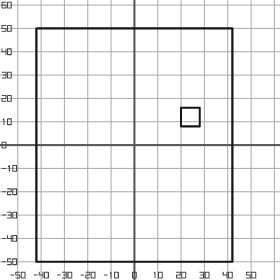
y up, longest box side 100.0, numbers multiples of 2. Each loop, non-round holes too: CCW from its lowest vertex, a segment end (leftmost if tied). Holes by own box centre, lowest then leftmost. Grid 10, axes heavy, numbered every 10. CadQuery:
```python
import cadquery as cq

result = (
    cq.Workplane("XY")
    .moveTo(-42.0, -50.0)
    .lineTo(42.0, -50.0)
    .lineTo(42.0, 50.0)
    .lineTo(-42.0, 50.0)
    .close()
    .moveTo(20.0, 8.0)
    .lineTo(28.0, 8.0)
    .lineTo(28.0, 16.0)
    .lineTo(20.0, 16.0)
    .close()
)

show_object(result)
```